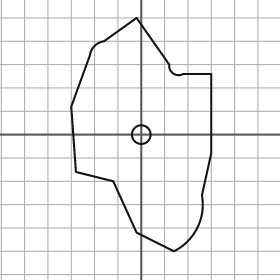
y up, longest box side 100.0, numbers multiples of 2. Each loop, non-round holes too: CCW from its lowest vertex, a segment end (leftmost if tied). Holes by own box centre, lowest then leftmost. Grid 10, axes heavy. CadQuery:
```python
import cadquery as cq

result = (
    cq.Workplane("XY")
    .moveTo(14.0, -50.0)
    .threePointArc((24.0, -40.0), (26.0, -26.0))
    .lineTo(30.0, -8.0)
    .lineTo(30.0, 26.0)
    .lineTo(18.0, 26.0)
    .threePointArc((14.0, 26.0), (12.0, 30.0))
    .lineTo(-2.0, 50.0)
    .lineTo(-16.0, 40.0)
    .threePointArc((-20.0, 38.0), (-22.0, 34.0))
    .lineTo(-30.0, 12.0)
    .lineTo(-28.0, -16.0)
    .lineTo(-12.0, -20.0)
    .lineTo(-2.0, -42.0)
    .close()
    .moveTo(0.0, 0.0)
    .circle(4.0)
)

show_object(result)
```